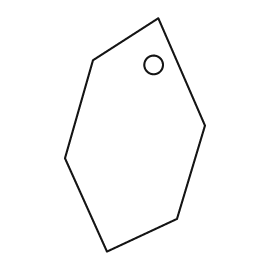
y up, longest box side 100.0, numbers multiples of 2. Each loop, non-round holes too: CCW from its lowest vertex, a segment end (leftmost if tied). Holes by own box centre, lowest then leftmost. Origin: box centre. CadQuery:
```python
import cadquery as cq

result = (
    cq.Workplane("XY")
    .moveTo(-12.0, -50.0)
    .lineTo(18.0, -36.0)
    .lineTo(30.0, 4.0)
    .lineTo(10.0, 50.0)
    .lineTo(-18.0, 32.0)
    .lineTo(-30.0, -10.0)
    .close()
    .moveTo(8.0, 30.0)
    .circle(4.0)
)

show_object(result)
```